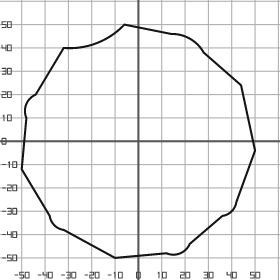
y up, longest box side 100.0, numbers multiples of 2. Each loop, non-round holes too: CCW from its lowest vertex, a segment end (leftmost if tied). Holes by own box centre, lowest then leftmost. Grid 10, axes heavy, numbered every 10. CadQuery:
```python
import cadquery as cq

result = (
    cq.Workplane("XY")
    .moveTo(-10.0, -50.0)
    .lineTo(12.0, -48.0)
    .threePointArc((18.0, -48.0), (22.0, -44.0))
    .lineTo(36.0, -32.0)
    .threePointArc((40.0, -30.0), (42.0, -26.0))
    .lineTo(50.0, -4.0)
    .lineTo(44.0, 24.0)
    .lineTo(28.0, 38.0)
    .threePointArc((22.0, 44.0), (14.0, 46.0))
    .lineTo(-6.0, 50.0)
    .threePointArc((-18.0, 42.0), (-32.0, 40.0))
    .lineTo(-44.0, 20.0)
    .threePointArc((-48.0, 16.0), (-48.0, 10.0))
    .lineTo(-50.0, -12.0)
    .lineTo(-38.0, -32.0)
    .threePointArc((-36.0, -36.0), (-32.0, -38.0))
    .close()
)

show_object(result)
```